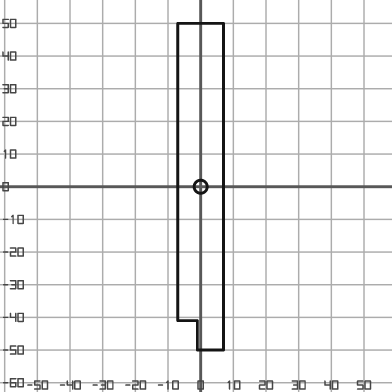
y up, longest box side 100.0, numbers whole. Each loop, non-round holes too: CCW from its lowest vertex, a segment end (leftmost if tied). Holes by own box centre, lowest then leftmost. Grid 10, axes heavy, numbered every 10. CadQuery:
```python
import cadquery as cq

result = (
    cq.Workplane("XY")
    .moveTo(-1.0, -50.0)
    .lineTo(7.0, -50.0)
    .lineTo(7.0, 50.0)
    .lineTo(-7.0, 50.0)
    .lineTo(-7.0, -41.0)
    .lineTo(-1.0, -41.0)
    .close()
    .moveTo(0.0, 0.0)
    .circle(2.0)
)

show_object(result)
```